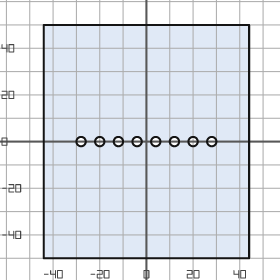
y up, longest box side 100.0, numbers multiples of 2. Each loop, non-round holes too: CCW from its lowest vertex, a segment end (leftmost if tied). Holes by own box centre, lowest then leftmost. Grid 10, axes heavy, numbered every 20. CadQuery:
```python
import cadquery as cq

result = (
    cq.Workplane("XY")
    .moveTo(-44.0, -50.0)
    .lineTo(44.0, -50.0)
    .lineTo(44.0, 50.0)
    .lineTo(-44.0, 50.0)
    .close()
    .moveTo(-28.0, 0.0)
    .circle(2.0)
    .moveTo(-20.0, 0.0)
    .circle(2.0)
    .moveTo(-12.0, 0.0)
    .circle(2.0)
    .moveTo(-4.0, 0.0)
    .circle(2.0)
    .moveTo(4.0, 0.0)
    .circle(2.0)
    .moveTo(12.0, 0.0)
    .circle(2.0)
    .moveTo(20.0, 0.0)
    .circle(2.0)
    .moveTo(28.0, 0.0)
    .circle(2.0)
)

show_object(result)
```